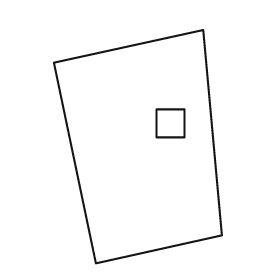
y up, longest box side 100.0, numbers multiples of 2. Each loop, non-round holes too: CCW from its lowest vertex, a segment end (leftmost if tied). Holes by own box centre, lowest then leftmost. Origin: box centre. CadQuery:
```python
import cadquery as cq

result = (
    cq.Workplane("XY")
    .moveTo(-18.0, -50.0)
    .lineTo(36.0, -38.0)
    .lineTo(28.0, 50.0)
    .lineTo(-36.0, 36.0)
    .close()
    .moveTo(8.0, 4.0)
    .lineTo(20.0, 4.0)
    .lineTo(20.0, 16.0)
    .lineTo(8.0, 16.0)
    .close()
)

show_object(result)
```